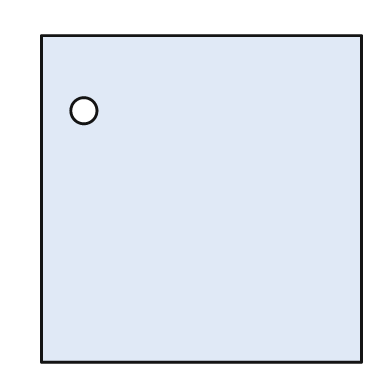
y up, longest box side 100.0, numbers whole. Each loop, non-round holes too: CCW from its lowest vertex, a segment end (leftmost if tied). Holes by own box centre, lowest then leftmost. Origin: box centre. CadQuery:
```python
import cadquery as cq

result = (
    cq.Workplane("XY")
    .moveTo(-49.0, -50.0)
    .lineTo(49.0, -50.0)
    .lineTo(49.0, 50.0)
    .lineTo(-49.0, 50.0)
    .close()
    .moveTo(-36.0, 27.0)
    .circle(4.0)
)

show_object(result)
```